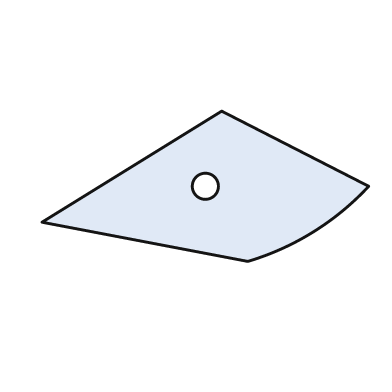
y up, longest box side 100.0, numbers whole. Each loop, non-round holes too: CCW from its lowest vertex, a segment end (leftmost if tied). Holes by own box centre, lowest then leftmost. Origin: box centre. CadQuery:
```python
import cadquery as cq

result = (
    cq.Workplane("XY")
    .moveTo(13.0, -23.0)
    .threePointArc((33.0, -14.0), (50.0, 0.0))
    .lineTo(5.0, 23.0)
    .lineTo(-50.0, -11.0)
    .close()
    .moveTo(0.0, 0.0)
    .circle(4.0)
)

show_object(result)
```